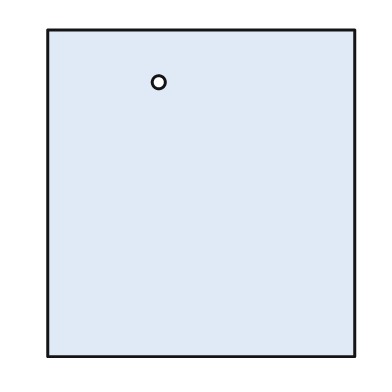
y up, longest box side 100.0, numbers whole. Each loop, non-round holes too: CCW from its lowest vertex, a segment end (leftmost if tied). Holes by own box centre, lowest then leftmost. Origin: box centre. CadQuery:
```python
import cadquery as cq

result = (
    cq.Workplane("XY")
    .moveTo(-47.0, -50.0)
    .lineTo(47.0, -50.0)
    .lineTo(47.0, 50.0)
    .lineTo(-47.0, 50.0)
    .close()
    .moveTo(-13.0, 34.0)
    .circle(2.0)
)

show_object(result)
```